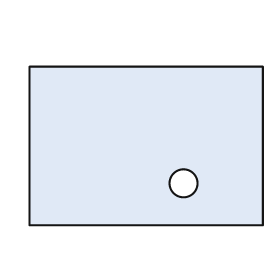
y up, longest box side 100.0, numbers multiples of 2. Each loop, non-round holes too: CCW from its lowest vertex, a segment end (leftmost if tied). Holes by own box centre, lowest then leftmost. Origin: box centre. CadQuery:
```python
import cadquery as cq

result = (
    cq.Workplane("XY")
    .moveTo(-50.0, -34.0)
    .lineTo(50.0, -34.0)
    .lineTo(50.0, 34.0)
    .lineTo(-50.0, 34.0)
    .close()
    .moveTo(16.0, -16.0)
    .circle(6.0)
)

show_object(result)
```